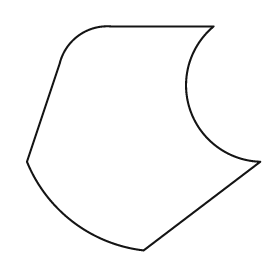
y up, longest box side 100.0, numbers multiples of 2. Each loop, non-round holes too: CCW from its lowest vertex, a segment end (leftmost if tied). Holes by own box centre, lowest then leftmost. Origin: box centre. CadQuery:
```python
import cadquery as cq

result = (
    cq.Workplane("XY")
    .moveTo(0.0, -48.0)
    .lineTo(50.0, -10.0)
    .threePointArc((20.0, 12.0), (30.0, 48.0))
    .lineTo(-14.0, 48.0)
    .threePointArc((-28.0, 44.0), (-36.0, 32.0))
    .lineTo(-50.0, -10.0)
    .threePointArc((-30.0, -36.0), (0.0, -48.0))
    .close()
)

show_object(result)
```